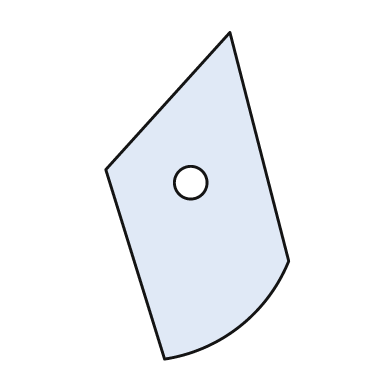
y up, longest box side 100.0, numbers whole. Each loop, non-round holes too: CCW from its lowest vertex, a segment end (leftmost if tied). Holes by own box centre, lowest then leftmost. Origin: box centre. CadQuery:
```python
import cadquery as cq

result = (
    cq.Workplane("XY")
    .moveTo(-10.0, -50.0)
    .threePointArc((13.0, -40.0), (28.0, -20.0))
    .lineTo(10.0, 50.0)
    .lineTo(-28.0, 8.0)
    .close()
    .moveTo(-2.0, 4.0)
    .circle(5.0)
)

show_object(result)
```